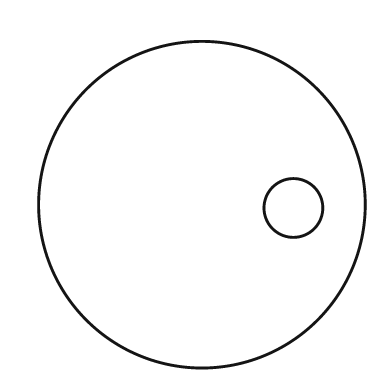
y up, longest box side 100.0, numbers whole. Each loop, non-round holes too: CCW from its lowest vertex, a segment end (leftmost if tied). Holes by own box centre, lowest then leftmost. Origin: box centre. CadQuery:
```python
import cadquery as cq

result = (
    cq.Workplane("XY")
    .moveTo(0.0, 0.0)
    .circle(50.0)
    .moveTo(28.0, -1.0)
    .circle(9.0)
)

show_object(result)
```